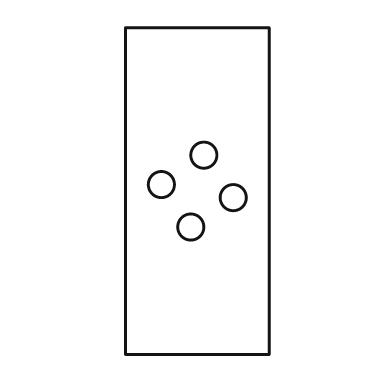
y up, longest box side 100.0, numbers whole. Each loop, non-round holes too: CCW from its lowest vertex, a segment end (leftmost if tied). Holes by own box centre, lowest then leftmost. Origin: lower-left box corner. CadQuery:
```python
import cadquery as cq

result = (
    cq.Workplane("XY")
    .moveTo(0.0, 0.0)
    .lineTo(44.0, 0.0)
    .lineTo(44.0, 100.0)
    .lineTo(0.0, 100.0)
    .close()
    .moveTo(20.0, 39.0)
    .circle(4.0)
    .moveTo(33.0, 48.0)
    .circle(4.0)
    .moveTo(11.0, 52.0)
    .circle(4.0)
    .moveTo(24.0, 61.0)
    .circle(4.0)
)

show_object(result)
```